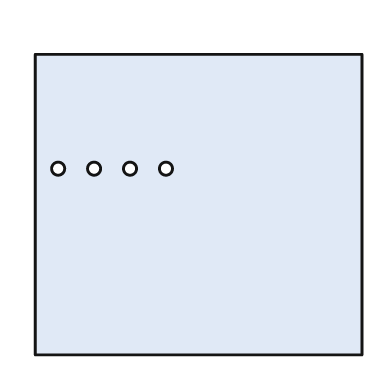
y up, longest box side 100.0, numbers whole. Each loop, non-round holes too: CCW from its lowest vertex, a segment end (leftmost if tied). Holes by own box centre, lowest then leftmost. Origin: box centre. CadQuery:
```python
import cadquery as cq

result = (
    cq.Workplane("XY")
    .moveTo(-50.0, -46.0)
    .lineTo(50.0, -46.0)
    .lineTo(50.0, 46.0)
    .lineTo(-50.0, 46.0)
    .close()
    .moveTo(-43.0, 11.0)
    .circle(2.0)
    .moveTo(-32.0, 11.0)
    .circle(2.0)
    .moveTo(-21.0, 11.0)
    .circle(2.0)
    .moveTo(-10.0, 11.0)
    .circle(2.0)
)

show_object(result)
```